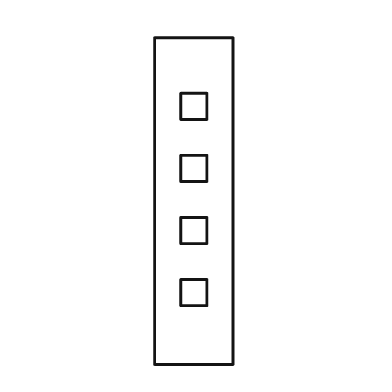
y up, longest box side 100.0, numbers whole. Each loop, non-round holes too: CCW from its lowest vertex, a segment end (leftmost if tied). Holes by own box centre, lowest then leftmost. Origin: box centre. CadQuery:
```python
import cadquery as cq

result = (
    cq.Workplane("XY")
    .moveTo(-12.0, -50.0)
    .lineTo(12.0, -50.0)
    .lineTo(12.0, 50.0)
    .lineTo(-12.0, 50.0)
    .close()
    .moveTo(-4.0, -32.0)
    .lineTo(4.0, -32.0)
    .lineTo(4.0, -24.0)
    .lineTo(-4.0, -24.0)
    .close()
    .moveTo(-4.0, -13.0)
    .lineTo(4.0, -13.0)
    .lineTo(4.0, -5.0)
    .lineTo(-4.0, -5.0)
    .close()
    .moveTo(-4.0, 6.0)
    .lineTo(4.0, 6.0)
    .lineTo(4.0, 14.0)
    .lineTo(-4.0, 14.0)
    .close()
    .moveTo(-4.0, 25.0)
    .lineTo(4.0, 25.0)
    .lineTo(4.0, 33.0)
    .lineTo(-4.0, 33.0)
    .close()
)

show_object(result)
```